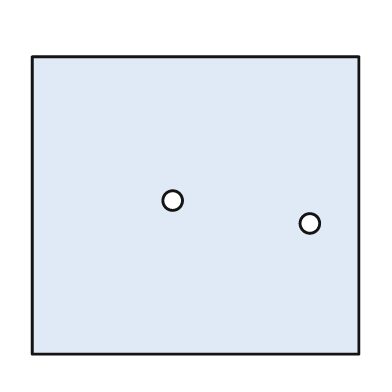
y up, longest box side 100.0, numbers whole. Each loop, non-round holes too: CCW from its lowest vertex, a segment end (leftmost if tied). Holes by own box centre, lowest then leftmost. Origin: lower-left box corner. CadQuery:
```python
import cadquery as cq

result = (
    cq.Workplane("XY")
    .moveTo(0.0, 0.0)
    .lineTo(100.0, 0.0)
    .lineTo(100.0, 91.0)
    .lineTo(0.0, 91.0)
    .close()
    .moveTo(85.0, 40.0)
    .circle(3.0)
    .moveTo(43.0, 47.0)
    .circle(3.0)
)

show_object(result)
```